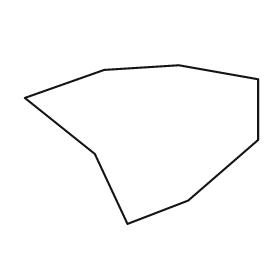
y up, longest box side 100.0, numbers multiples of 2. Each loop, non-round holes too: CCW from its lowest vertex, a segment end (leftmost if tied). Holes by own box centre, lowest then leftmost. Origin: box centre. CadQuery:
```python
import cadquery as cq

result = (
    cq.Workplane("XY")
    .moveTo(-6.0, -34.0)
    .lineTo(20.0, -24.0)
    .lineTo(50.0, 2.0)
    .lineTo(50.0, 28.0)
    .lineTo(16.0, 34.0)
    .lineTo(-16.0, 32.0)
    .lineTo(-50.0, 20.0)
    .lineTo(-20.0, -4.0)
    .close()
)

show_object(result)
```